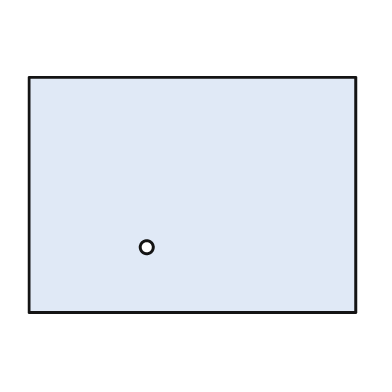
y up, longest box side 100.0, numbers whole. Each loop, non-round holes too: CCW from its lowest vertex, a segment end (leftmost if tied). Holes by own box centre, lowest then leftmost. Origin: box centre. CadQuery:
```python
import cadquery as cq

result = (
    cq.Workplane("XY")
    .moveTo(-50.0, -36.0)
    .lineTo(50.0, -36.0)
    .lineTo(50.0, 36.0)
    .lineTo(-50.0, 36.0)
    .close()
    .moveTo(-14.0, -16.0)
    .circle(2.0)
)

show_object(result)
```